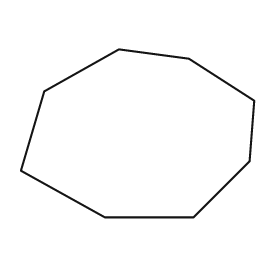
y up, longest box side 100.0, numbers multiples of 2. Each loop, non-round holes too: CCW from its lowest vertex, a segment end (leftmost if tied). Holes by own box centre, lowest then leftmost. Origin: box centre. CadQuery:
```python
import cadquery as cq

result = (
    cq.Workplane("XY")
    .moveTo(-14.0, -36.0)
    .lineTo(24.0, -36.0)
    .lineTo(48.0, -12.0)
    .lineTo(50.0, 14.0)
    .lineTo(22.0, 32.0)
    .lineTo(-8.0, 36.0)
    .lineTo(-40.0, 18.0)
    .lineTo(-50.0, -16.0)
    .close()
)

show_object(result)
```